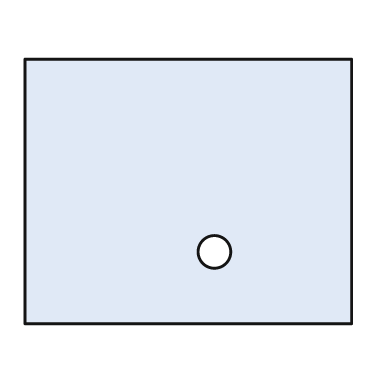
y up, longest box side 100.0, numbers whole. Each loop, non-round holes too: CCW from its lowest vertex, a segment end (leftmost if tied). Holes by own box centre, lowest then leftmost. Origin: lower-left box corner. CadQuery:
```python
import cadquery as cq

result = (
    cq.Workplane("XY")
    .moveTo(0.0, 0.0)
    .lineTo(100.0, 0.0)
    .lineTo(100.0, 81.0)
    .lineTo(0.0, 81.0)
    .close()
    .moveTo(58.0, 22.0)
    .circle(5.0)
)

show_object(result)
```